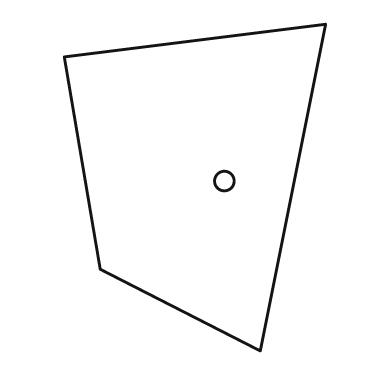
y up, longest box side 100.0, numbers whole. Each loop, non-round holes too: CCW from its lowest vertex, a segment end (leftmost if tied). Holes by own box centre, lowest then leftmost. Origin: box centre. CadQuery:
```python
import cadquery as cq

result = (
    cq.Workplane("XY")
    .moveTo(20.0, -50.0)
    .lineTo(40.0, 50.0)
    .lineTo(-40.0, 40.0)
    .lineTo(-29.0, -25.0)
    .close()
    .moveTo(9.0, 2.0)
    .circle(3.0)
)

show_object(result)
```